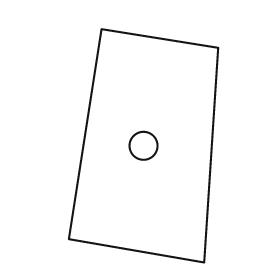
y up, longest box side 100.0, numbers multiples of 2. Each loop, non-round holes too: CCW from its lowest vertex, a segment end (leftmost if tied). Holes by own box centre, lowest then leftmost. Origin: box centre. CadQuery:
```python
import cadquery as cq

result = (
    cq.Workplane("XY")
    .moveTo(26.0, -50.0)
    .lineTo(32.0, 42.0)
    .lineTo(-18.0, 50.0)
    .lineTo(-32.0, -40.0)
    .close()
    .moveTo(0.0, 0.0)
    .circle(6.0)
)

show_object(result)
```